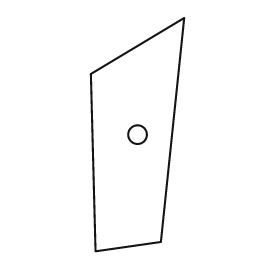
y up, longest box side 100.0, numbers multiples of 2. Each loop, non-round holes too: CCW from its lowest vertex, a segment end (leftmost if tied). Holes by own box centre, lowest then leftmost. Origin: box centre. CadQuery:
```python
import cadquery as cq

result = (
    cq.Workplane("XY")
    .moveTo(-18.0, -50.0)
    .lineTo(10.0, -46.0)
    .lineTo(20.0, 50.0)
    .lineTo(-20.0, 26.0)
    .close()
    .moveTo(0.0, 0.0)
    .circle(4.0)
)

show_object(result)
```